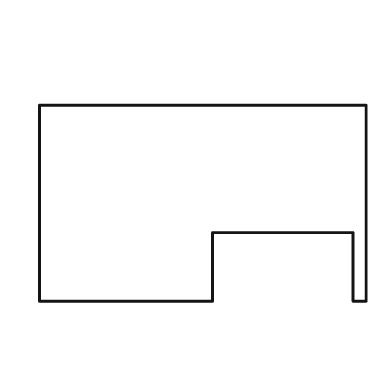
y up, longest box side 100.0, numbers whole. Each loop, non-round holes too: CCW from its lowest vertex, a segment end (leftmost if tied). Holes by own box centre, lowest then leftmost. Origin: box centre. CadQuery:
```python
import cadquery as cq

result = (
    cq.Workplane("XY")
    .moveTo(-50.0, -30.0)
    .lineTo(3.0, -30.0)
    .lineTo(3.0, -9.0)
    .lineTo(46.0, -9.0)
    .lineTo(46.0, -30.0)
    .lineTo(50.0, -30.0)
    .lineTo(50.0, 30.0)
    .lineTo(-50.0, 30.0)
    .close()
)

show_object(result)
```